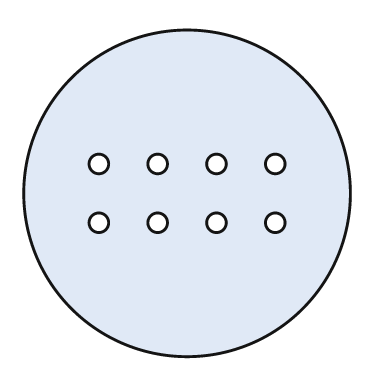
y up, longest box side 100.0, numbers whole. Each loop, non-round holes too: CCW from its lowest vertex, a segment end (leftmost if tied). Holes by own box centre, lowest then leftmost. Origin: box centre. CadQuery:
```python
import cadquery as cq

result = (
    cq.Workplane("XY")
    .moveTo(0.0, 0.0)
    .circle(50.0)
    .moveTo(-27.0, -9.0)
    .circle(3.0)
    .moveTo(-9.0, -9.0)
    .circle(3.0)
    .moveTo(9.0, -9.0)
    .circle(3.0)
    .moveTo(27.0, -9.0)
    .circle(3.0)
    .moveTo(-27.0, 9.0)
    .circle(3.0)
    .moveTo(-9.0, 9.0)
    .circle(3.0)
    .moveTo(9.0, 9.0)
    .circle(3.0)
    .moveTo(27.0, 9.0)
    .circle(3.0)
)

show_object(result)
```